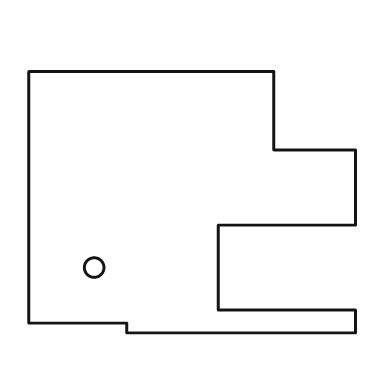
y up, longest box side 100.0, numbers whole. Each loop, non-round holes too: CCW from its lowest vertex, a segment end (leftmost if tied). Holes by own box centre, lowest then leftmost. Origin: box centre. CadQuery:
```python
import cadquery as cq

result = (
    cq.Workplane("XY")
    .moveTo(-20.0, -40.0)
    .lineTo(50.0, -40.0)
    .lineTo(50.0, -33.0)
    .lineTo(8.0, -33.0)
    .lineTo(8.0, -7.0)
    .lineTo(50.0, -7.0)
    .lineTo(50.0, 16.0)
    .lineTo(25.0, 16.0)
    .lineTo(25.0, 40.0)
    .lineTo(-50.0, 40.0)
    .lineTo(-50.0, -37.0)
    .lineTo(-20.0, -37.0)
    .close()
    .moveTo(-30.0, -20.0)
    .circle(3.0)
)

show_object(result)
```